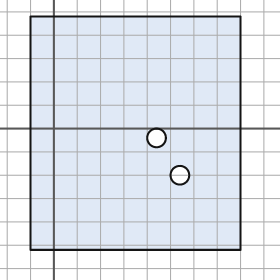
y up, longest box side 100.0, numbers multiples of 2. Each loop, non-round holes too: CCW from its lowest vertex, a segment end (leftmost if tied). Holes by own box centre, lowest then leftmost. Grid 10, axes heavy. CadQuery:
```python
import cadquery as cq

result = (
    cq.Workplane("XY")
    .moveTo(-10.0, -52.0)
    .lineTo(80.0, -52.0)
    .lineTo(80.0, 48.0)
    .lineTo(-10.0, 48.0)
    .close()
    .moveTo(54.0, -20.0)
    .circle(4.0)
    .moveTo(44.0, -4.0)
    .circle(4.0)
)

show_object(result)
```